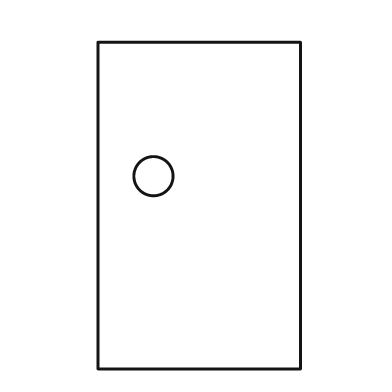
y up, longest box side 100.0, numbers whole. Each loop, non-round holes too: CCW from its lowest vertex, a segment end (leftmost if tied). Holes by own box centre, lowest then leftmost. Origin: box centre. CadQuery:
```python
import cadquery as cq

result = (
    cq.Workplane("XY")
    .moveTo(-31.0, -50.0)
    .lineTo(31.0, -50.0)
    .lineTo(31.0, 50.0)
    .lineTo(-31.0, 50.0)
    .close()
    .moveTo(-14.0, 9.0)
    .circle(6.0)
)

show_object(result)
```